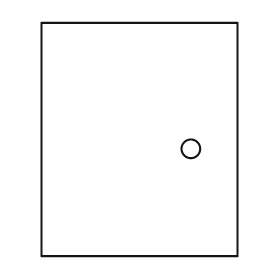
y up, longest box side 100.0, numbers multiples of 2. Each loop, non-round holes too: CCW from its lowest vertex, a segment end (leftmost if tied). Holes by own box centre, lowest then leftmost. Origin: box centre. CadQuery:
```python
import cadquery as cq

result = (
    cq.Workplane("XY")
    .moveTo(-42.0, -50.0)
    .lineTo(42.0, -50.0)
    .lineTo(42.0, 50.0)
    .lineTo(-42.0, 50.0)
    .close()
    .moveTo(22.0, -4.0)
    .circle(4.0)
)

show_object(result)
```